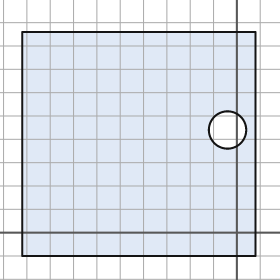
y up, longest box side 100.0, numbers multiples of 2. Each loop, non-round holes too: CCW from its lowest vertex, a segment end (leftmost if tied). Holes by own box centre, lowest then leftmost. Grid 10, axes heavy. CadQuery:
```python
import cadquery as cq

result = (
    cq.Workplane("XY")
    .moveTo(-92.0, -10.0)
    .lineTo(8.0, -10.0)
    .lineTo(8.0, 86.0)
    .lineTo(-92.0, 86.0)
    .close()
    .moveTo(-4.0, 44.0)
    .circle(8.0)
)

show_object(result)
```